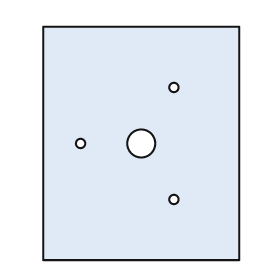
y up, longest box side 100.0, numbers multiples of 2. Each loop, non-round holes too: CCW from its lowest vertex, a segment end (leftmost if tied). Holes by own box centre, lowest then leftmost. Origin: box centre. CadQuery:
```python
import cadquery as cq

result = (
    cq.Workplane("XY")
    .moveTo(-42.0, -50.0)
    .lineTo(42.0, -50.0)
    .lineTo(42.0, 50.0)
    .lineTo(-42.0, 50.0)
    .close()
    .moveTo(14.0, -24.0)
    .circle(2.0)
    .moveTo(-26.0, 0.0)
    .circle(2.0)
    .moveTo(0.0, 0.0)
    .circle(6.0)
    .moveTo(14.0, 24.0)
    .circle(2.0)
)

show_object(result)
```